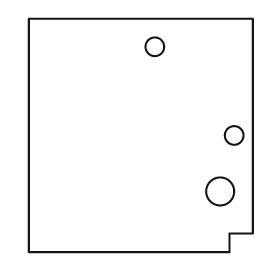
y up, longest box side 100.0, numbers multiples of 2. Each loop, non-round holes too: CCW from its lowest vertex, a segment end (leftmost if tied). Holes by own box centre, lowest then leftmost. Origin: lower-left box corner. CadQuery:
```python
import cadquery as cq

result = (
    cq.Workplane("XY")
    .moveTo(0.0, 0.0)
    .lineTo(86.0, 0.0)
    .lineTo(86.0, 8.0)
    .lineTo(96.0, 8.0)
    .lineTo(96.0, 100.0)
    .lineTo(0.0, 100.0)
    .close()
    .moveTo(82.0, 26.0)
    .circle(6.0)
    .moveTo(88.0, 50.0)
    .circle(4.0)
    .moveTo(54.0, 88.0)
    .circle(4.0)
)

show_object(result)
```